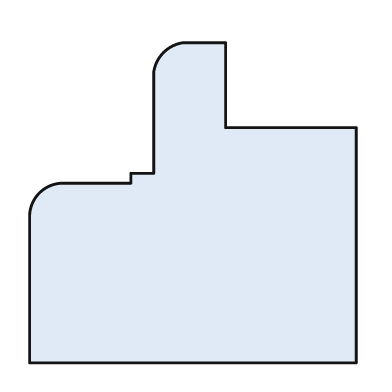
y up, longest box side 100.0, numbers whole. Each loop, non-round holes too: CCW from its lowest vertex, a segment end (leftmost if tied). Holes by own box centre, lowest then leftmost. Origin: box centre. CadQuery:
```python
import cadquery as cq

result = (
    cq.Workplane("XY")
    .moveTo(-50.0, -49.0)
    .lineTo(50.0, -49.0)
    .lineTo(50.0, 23.0)
    .lineTo(10.0, 23.0)
    .lineTo(10.0, 49.0)
    .lineTo(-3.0, 49.0)
    .threePointArc((-9.0, 46.0), (-12.0, 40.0))
    .lineTo(-12.0, 9.0)
    .lineTo(-19.0, 9.0)
    .lineTo(-19.0, 6.0)
    .lineTo(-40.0, 6.0)
    .threePointArc((-47.0, 3.0), (-50.0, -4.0))
    .close()
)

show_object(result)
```